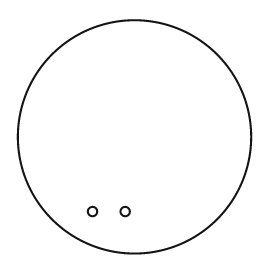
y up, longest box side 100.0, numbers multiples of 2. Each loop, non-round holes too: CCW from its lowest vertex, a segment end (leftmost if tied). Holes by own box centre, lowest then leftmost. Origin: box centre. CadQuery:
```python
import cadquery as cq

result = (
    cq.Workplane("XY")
    .moveTo(0.0, 0.0)
    .circle(50.0)
    .moveTo(-18.0, -32.0)
    .circle(2.0)
    .moveTo(-4.0, -32.0)
    .circle(2.0)
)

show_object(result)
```